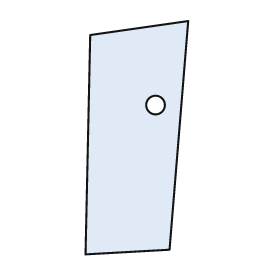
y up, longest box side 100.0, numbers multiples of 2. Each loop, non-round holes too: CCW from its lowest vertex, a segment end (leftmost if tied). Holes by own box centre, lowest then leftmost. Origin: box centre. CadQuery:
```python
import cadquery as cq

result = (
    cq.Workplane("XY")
    .moveTo(-22.0, -50.0)
    .lineTo(14.0, -48.0)
    .lineTo(22.0, 50.0)
    .lineTo(-20.0, 44.0)
    .close()
    .moveTo(8.0, 14.0)
    .circle(4.0)
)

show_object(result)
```